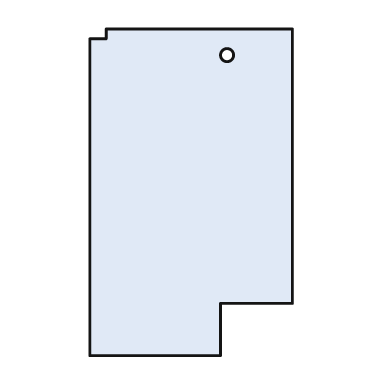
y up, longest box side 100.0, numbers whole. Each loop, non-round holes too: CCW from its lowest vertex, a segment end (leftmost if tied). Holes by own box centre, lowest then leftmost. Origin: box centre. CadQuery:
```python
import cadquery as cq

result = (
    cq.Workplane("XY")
    .moveTo(-31.0, -50.0)
    .lineTo(9.0, -50.0)
    .lineTo(9.0, -34.0)
    .lineTo(31.0, -34.0)
    .lineTo(31.0, 50.0)
    .lineTo(-26.0, 50.0)
    .lineTo(-26.0, 47.0)
    .lineTo(-31.0, 47.0)
    .close()
    .moveTo(11.0, 42.0)
    .circle(2.0)
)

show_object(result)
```